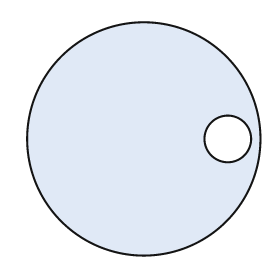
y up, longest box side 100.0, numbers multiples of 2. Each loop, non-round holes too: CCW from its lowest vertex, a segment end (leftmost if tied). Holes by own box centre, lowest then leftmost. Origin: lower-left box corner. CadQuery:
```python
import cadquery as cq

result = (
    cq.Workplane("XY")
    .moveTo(50.0, 50.0)
    .circle(50.0)
    .moveTo(86.0, 50.0)
    .circle(10.0)
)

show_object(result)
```